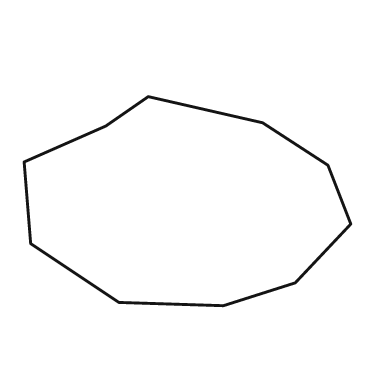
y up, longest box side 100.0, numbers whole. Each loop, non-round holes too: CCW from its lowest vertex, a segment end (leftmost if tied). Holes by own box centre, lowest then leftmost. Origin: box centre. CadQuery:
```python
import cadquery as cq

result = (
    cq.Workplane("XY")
    .moveTo(11.0, -32.0)
    .lineTo(33.0, -25.0)
    .lineTo(50.0, -7.0)
    .lineTo(43.0, 11.0)
    .lineTo(23.0, 24.0)
    .lineTo(-12.0, 32.0)
    .lineTo(-25.0, 23.0)
    .lineTo(-50.0, 12.0)
    .lineTo(-48.0, -13.0)
    .lineTo(-21.0, -31.0)
    .close()
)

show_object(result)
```